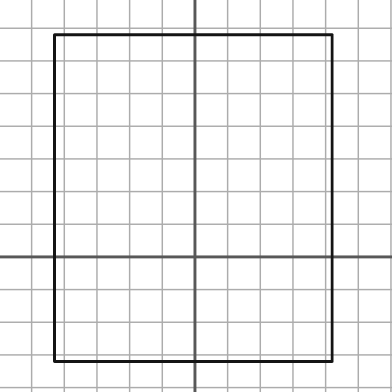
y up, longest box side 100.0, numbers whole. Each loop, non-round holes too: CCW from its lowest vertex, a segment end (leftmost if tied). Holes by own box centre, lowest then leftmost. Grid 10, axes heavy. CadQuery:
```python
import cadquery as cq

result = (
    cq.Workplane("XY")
    .moveTo(-43.0, -32.0)
    .lineTo(42.0, -32.0)
    .lineTo(42.0, 68.0)
    .lineTo(-43.0, 68.0)
    .close()
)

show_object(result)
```